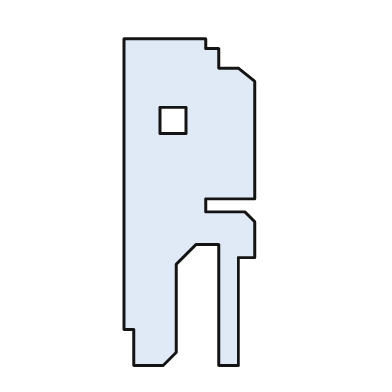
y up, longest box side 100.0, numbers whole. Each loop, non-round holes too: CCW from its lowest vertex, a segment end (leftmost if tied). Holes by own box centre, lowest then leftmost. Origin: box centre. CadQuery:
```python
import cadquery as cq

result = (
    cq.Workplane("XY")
    .moveTo(-17.0, -50.0)
    .lineTo(-8.0, -50.0)
    .lineTo(-4.0, -46.0)
    .lineTo(-4.0, -19.0)
    .lineTo(2.0, -13.0)
    .lineTo(9.0, -13.0)
    .lineTo(9.0, -50.0)
    .lineTo(15.0, -50.0)
    .lineTo(15.0, -17.0)
    .lineTo(20.0, -17.0)
    .lineTo(20.0, -6.0)
    .lineTo(17.0, -3.0)
    .lineTo(5.0, -3.0)
    .lineTo(5.0, 1.0)
    .lineTo(20.0, 1.0)
    .lineTo(20.0, 37.0)
    .lineTo(15.0, 41.0)
    .lineTo(9.0, 41.0)
    .lineTo(9.0, 47.0)
    .lineTo(5.0, 47.0)
    .lineTo(5.0, 50.0)
    .lineTo(-20.0, 50.0)
    .lineTo(-20.0, -39.0)
    .lineTo(-17.0, -39.0)
    .close()
    .moveTo(-9.0, 21.0)
    .lineTo(-1.0, 21.0)
    .lineTo(-1.0, 29.0)
    .lineTo(-9.0, 29.0)
    .close()
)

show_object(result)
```